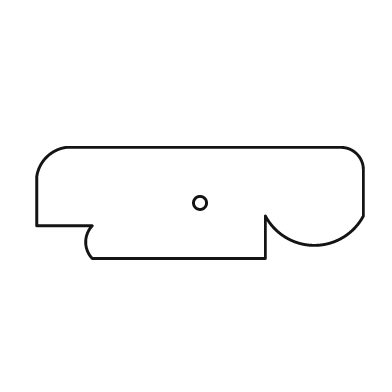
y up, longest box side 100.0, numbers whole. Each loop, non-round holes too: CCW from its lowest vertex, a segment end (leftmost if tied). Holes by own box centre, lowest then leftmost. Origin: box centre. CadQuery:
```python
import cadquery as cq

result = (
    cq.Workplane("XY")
    .moveTo(-33.0, -17.0)
    .lineTo(20.0, -17.0)
    .lineTo(20.0, -4.0)
    .threePointArc((35.0, -13.0), (50.0, -4.0))
    .lineTo(50.0, 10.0)
    .threePointArc((48.0, 15.0), (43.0, 17.0))
    .lineTo(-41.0, 17.0)
    .threePointArc((-47.0, 14.0), (-50.0, 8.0))
    .lineTo(-50.0, -7.0)
    .lineTo(-33.0, -7.0)
    .threePointArc((-35.0, -12.0), (-33.0, -17.0))
    .close()
    .moveTo(0.0, 0.0)
    .circle(2.0)
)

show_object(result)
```